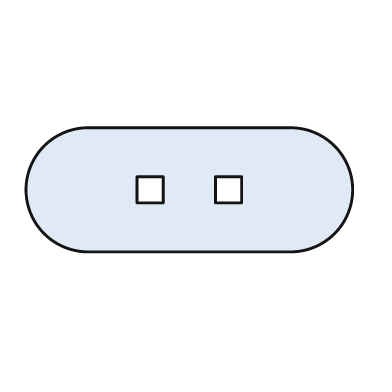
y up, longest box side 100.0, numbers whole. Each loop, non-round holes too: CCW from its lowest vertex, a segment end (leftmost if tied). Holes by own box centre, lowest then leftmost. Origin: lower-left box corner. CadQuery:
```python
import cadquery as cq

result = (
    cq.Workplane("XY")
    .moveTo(19.0, 0.0)
    .lineTo(81.0, 0.0)
    .threePointArc((100.0, 19.0), (81.0, 38.0))
    .lineTo(19.0, 38.0)
    .threePointArc((0.0, 19.0), (19.0, 0.0))
    .close()
    .moveTo(34.0, 15.0)
    .lineTo(42.0, 15.0)
    .lineTo(42.0, 23.0)
    .lineTo(34.0, 23.0)
    .close()
    .moveTo(58.0, 15.0)
    .lineTo(66.0, 15.0)
    .lineTo(66.0, 23.0)
    .lineTo(58.0, 23.0)
    .close()
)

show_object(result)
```